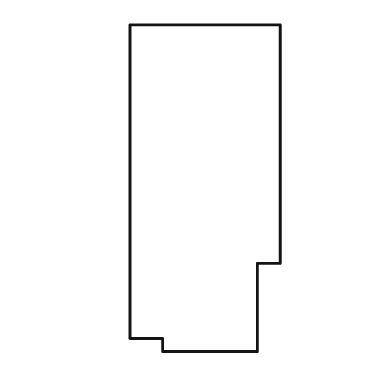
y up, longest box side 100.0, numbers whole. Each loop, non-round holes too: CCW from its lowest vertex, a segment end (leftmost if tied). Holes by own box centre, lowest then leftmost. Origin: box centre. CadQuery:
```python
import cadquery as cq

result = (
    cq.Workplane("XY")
    .moveTo(-13.0, -50.0)
    .lineTo(16.0, -50.0)
    .lineTo(16.0, -23.0)
    .lineTo(23.0, -23.0)
    .lineTo(23.0, 50.0)
    .lineTo(-23.0, 50.0)
    .lineTo(-23.0, -46.0)
    .lineTo(-13.0, -46.0)
    .close()
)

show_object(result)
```